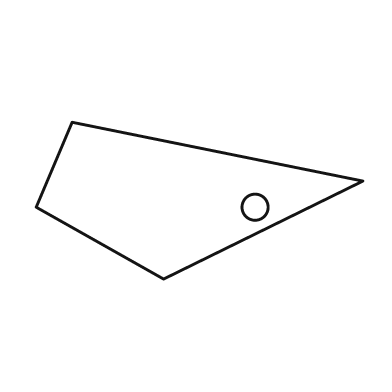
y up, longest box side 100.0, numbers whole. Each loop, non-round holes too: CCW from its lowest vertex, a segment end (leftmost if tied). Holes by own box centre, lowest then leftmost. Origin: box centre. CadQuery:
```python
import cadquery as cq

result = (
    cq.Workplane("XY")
    .moveTo(-11.0, -24.0)
    .lineTo(50.0, 6.0)
    .lineTo(-39.0, 24.0)
    .lineTo(-50.0, -2.0)
    .close()
    .moveTo(17.0, -2.0)
    .circle(4.0)
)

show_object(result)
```